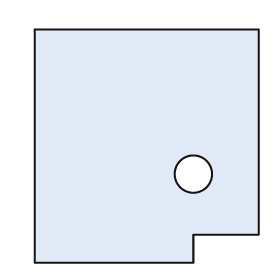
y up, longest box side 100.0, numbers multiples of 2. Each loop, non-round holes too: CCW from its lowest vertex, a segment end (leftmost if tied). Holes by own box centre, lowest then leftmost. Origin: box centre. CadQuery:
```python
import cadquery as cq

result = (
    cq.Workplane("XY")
    .moveTo(-48.0, -50.0)
    .lineTo(20.0, -50.0)
    .lineTo(20.0, -38.0)
    .lineTo(48.0, -38.0)
    .lineTo(48.0, 50.0)
    .lineTo(-48.0, 50.0)
    .close()
    .moveTo(20.0, -12.0)
    .circle(8.0)
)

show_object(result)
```